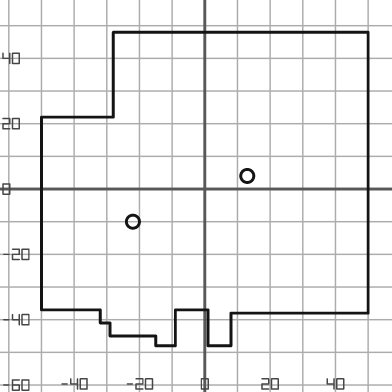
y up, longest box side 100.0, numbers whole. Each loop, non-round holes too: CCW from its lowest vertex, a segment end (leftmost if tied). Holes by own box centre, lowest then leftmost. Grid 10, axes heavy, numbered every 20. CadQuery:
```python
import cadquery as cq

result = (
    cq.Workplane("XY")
    .moveTo(-15.0, -48.0)
    .lineTo(-9.0, -48.0)
    .lineTo(-9.0, -37.0)
    .lineTo(1.0, -37.0)
    .lineTo(1.0, -48.0)
    .lineTo(8.0, -48.0)
    .lineTo(8.0, -38.0)
    .lineTo(50.0, -38.0)
    .lineTo(50.0, 48.0)
    .lineTo(-28.0, 48.0)
    .lineTo(-28.0, 22.0)
    .lineTo(-50.0, 22.0)
    .lineTo(-50.0, -37.0)
    .lineTo(-32.0, -37.0)
    .lineTo(-32.0, -41.0)
    .lineTo(-29.0, -41.0)
    .lineTo(-29.0, -45.0)
    .lineTo(-15.0, -45.0)
    .close()
    .moveTo(-22.0, -10.0)
    .circle(2.0)
    .moveTo(13.0, 4.0)
    .circle(2.0)
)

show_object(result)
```